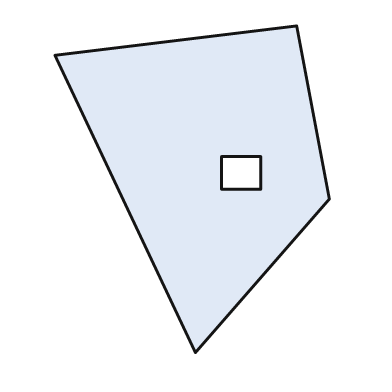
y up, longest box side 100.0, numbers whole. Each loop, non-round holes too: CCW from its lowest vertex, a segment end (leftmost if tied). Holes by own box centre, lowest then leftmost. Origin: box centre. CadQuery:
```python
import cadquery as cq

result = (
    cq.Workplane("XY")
    .moveTo(1.0, -50.0)
    .lineTo(42.0, -3.0)
    .lineTo(32.0, 50.0)
    .lineTo(-42.0, 41.0)
    .close()
    .moveTo(9.0, 0.0)
    .lineTo(21.0, 0.0)
    .lineTo(21.0, 10.0)
    .lineTo(9.0, 10.0)
    .close()
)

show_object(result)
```